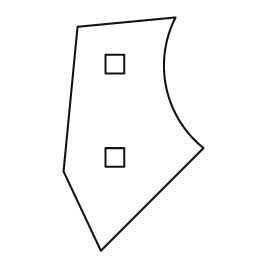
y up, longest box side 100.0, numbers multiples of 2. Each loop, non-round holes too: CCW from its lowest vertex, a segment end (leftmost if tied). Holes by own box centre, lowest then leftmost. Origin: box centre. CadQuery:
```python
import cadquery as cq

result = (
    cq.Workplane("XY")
    .moveTo(-14.0, -50.0)
    .lineTo(30.0, -6.0)
    .threePointArc((14.0, 20.0), (18.0, 50.0))
    .lineTo(-24.0, 46.0)
    .lineTo(-30.0, -16.0)
    .close()
    .moveTo(-12.0, -14.0)
    .lineTo(-4.0, -14.0)
    .lineTo(-4.0, -6.0)
    .lineTo(-12.0, -6.0)
    .close()
    .moveTo(-12.0, 26.0)
    .lineTo(-4.0, 26.0)
    .lineTo(-4.0, 34.0)
    .lineTo(-12.0, 34.0)
    .close()
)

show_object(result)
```